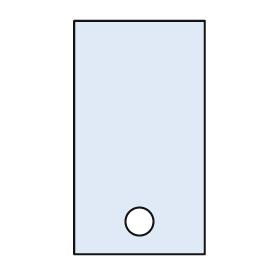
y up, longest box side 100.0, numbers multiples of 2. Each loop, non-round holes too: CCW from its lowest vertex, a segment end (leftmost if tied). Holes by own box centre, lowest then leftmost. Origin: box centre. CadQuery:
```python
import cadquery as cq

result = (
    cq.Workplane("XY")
    .moveTo(-28.0, -50.0)
    .lineTo(28.0, -50.0)
    .lineTo(28.0, 50.0)
    .lineTo(-28.0, 50.0)
    .close()
    .moveTo(0.0, -36.0)
    .circle(6.0)
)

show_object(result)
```